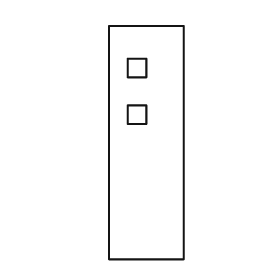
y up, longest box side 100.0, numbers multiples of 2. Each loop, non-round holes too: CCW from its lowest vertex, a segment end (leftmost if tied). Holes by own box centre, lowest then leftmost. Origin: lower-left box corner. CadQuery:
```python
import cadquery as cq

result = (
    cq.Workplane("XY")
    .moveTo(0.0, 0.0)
    .lineTo(32.0, 0.0)
    .lineTo(32.0, 100.0)
    .lineTo(0.0, 100.0)
    .close()
    .moveTo(8.0, 58.0)
    .lineTo(16.0, 58.0)
    .lineTo(16.0, 66.0)
    .lineTo(8.0, 66.0)
    .close()
    .moveTo(8.0, 78.0)
    .lineTo(16.0, 78.0)
    .lineTo(16.0, 86.0)
    .lineTo(8.0, 86.0)
    .close()
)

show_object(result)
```